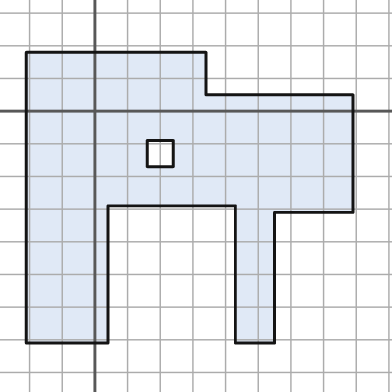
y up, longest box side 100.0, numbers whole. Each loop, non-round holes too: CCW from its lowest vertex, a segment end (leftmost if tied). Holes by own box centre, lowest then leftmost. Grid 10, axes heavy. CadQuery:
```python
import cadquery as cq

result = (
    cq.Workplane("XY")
    .moveTo(-21.0, -71.0)
    .lineTo(4.0, -71.0)
    .lineTo(4.0, -29.0)
    .lineTo(43.0, -29.0)
    .lineTo(43.0, -71.0)
    .lineTo(55.0, -71.0)
    .lineTo(55.0, -31.0)
    .lineTo(79.0, -31.0)
    .lineTo(79.0, 5.0)
    .lineTo(34.0, 5.0)
    .lineTo(34.0, 18.0)
    .lineTo(-21.0, 18.0)
    .close()
    .moveTo(16.0, -17.0)
    .lineTo(24.0, -17.0)
    .lineTo(24.0, -9.0)
    .lineTo(16.0, -9.0)
    .close()
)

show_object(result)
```